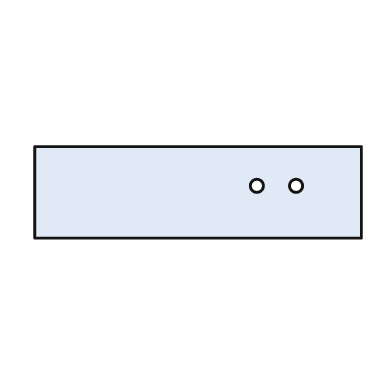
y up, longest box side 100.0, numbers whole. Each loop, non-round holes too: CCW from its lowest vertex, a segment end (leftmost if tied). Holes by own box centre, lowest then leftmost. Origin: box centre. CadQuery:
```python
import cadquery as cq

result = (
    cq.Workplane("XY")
    .moveTo(-50.0, -14.0)
    .lineTo(50.0, -14.0)
    .lineTo(50.0, 14.0)
    .lineTo(-50.0, 14.0)
    .close()
    .moveTo(18.0, 2.0)
    .circle(2.0)
    .moveTo(30.0, 2.0)
    .circle(2.0)
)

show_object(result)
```